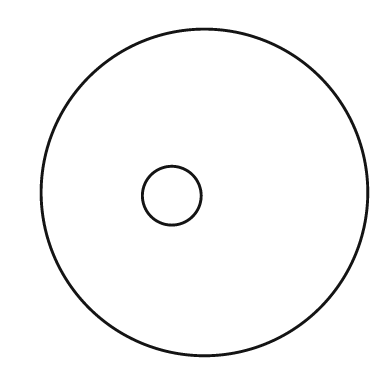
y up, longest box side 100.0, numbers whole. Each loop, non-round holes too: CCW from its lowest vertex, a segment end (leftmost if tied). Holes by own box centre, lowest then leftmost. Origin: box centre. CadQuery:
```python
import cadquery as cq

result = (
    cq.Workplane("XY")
    .moveTo(0.0, 0.0)
    .circle(50.0)
    .moveTo(-10.0, -1.0)
    .circle(9.0)
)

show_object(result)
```